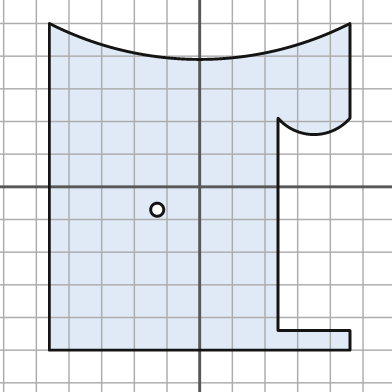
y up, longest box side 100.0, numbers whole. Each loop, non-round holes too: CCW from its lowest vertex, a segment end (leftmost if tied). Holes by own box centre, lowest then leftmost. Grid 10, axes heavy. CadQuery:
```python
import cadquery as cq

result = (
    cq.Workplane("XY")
    .moveTo(-46.0, -50.0)
    .lineTo(46.0, -50.0)
    .lineTo(46.0, -44.0)
    .lineTo(24.0, -44.0)
    .lineTo(24.0, 21.0)
    .threePointArc((35.0, 16.0), (46.0, 21.0))
    .lineTo(46.0, 50.0)
    .threePointArc((0.0, 39.0), (-46.0, 50.0))
    .close()
    .moveTo(-13.0, -7.0)
    .circle(2.0)
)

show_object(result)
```